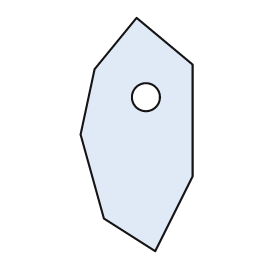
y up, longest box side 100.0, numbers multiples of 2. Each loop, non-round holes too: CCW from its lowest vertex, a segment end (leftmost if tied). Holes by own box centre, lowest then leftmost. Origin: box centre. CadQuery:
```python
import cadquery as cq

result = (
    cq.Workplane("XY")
    .moveTo(8.0, -50.0)
    .lineTo(24.0, -18.0)
    .lineTo(24.0, 30.0)
    .lineTo(0.0, 50.0)
    .lineTo(-18.0, 28.0)
    .lineTo(-24.0, 0.0)
    .lineTo(-14.0, -36.0)
    .close()
    .moveTo(4.0, 16.0)
    .circle(6.0)
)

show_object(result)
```